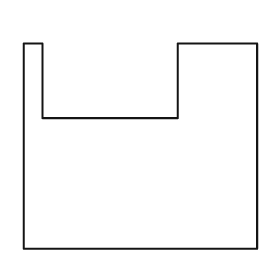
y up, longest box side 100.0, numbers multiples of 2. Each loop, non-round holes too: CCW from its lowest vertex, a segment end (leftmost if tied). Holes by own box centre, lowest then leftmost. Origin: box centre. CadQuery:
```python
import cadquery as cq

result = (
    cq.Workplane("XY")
    .moveTo(-50.0, -44.0)
    .lineTo(50.0, -44.0)
    .lineTo(50.0, 44.0)
    .lineTo(16.0, 44.0)
    .lineTo(16.0, 12.0)
    .lineTo(-42.0, 12.0)
    .lineTo(-42.0, 44.0)
    .lineTo(-50.0, 44.0)
    .close()
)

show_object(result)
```